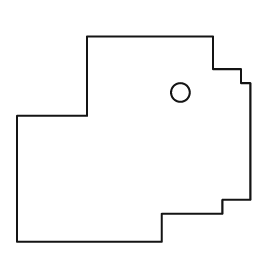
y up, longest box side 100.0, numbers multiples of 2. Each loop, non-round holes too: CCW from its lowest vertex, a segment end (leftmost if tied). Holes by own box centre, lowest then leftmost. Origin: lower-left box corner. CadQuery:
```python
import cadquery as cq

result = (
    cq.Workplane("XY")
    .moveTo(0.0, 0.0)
    .lineTo(62.0, 0.0)
    .lineTo(62.0, 12.0)
    .lineTo(88.0, 12.0)
    .lineTo(88.0, 18.0)
    .lineTo(100.0, 18.0)
    .lineTo(100.0, 68.0)
    .lineTo(96.0, 68.0)
    .lineTo(96.0, 74.0)
    .lineTo(84.0, 74.0)
    .lineTo(84.0, 88.0)
    .lineTo(30.0, 88.0)
    .lineTo(30.0, 54.0)
    .lineTo(0.0, 54.0)
    .close()
    .moveTo(70.0, 64.0)
    .circle(4.0)
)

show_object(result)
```